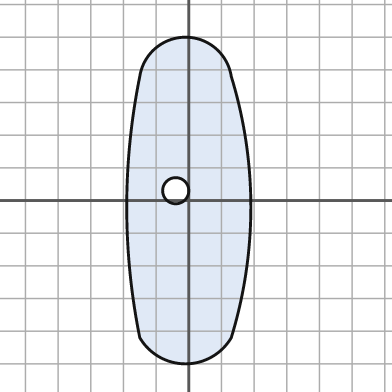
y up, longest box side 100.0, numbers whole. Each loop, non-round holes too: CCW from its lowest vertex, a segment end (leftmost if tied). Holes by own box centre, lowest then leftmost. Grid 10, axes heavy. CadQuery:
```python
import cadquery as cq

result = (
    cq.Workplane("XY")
    .moveTo(-15.0, -42.0)
    .threePointArc((-1.0, -50.0), (13.0, -42.0))
    .threePointArc((19.0, -2.0), (13.0, 38.0))
    .threePointArc((-1.0, 50.0), (-15.0, 38.0))
    .threePointArc((-19.0, -2.0), (-15.0, -42.0))
    .close()
    .moveTo(-4.0, 3.0)
    .circle(4.0)
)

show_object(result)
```